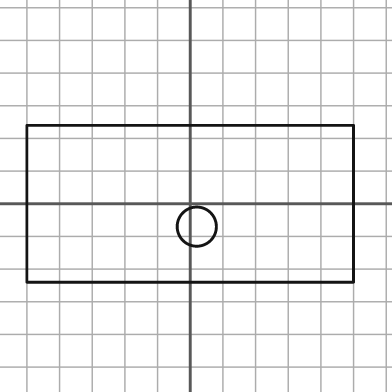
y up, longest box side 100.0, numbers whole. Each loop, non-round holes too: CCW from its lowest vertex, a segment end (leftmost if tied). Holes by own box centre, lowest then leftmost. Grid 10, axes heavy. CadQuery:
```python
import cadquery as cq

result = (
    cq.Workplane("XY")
    .moveTo(-50.0, -24.0)
    .lineTo(50.0, -24.0)
    .lineTo(50.0, 24.0)
    .lineTo(-50.0, 24.0)
    .close()
    .moveTo(2.0, -7.0)
    .circle(6.0)
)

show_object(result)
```